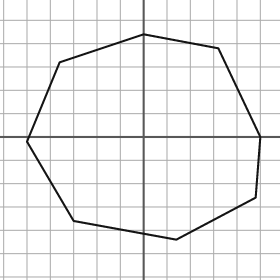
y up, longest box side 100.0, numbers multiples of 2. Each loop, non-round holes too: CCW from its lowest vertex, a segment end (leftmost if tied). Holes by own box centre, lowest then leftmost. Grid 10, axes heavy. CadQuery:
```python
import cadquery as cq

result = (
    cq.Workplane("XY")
    .moveTo(14.0, -44.0)
    .lineTo(48.0, -26.0)
    .lineTo(50.0, 0.0)
    .lineTo(32.0, 38.0)
    .lineTo(0.0, 44.0)
    .lineTo(-36.0, 32.0)
    .lineTo(-50.0, -2.0)
    .lineTo(-30.0, -36.0)
    .close()
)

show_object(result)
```